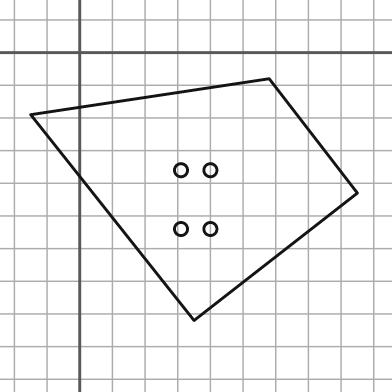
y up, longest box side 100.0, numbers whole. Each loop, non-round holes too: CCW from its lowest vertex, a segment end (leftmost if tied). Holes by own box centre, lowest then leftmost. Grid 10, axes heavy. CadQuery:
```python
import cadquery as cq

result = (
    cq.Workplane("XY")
    .moveTo(35.0, -82.0)
    .lineTo(85.0, -43.0)
    .lineTo(58.0, -8.0)
    .lineTo(-15.0, -19.0)
    .close()
    .moveTo(31.0, -54.0)
    .circle(2.0)
    .moveTo(40.0, -54.0)
    .circle(2.0)
    .moveTo(31.0, -36.0)
    .circle(2.0)
    .moveTo(40.0, -36.0)
    .circle(2.0)
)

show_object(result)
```